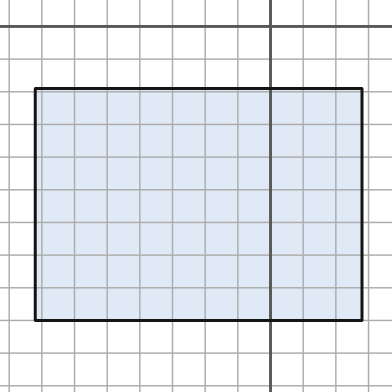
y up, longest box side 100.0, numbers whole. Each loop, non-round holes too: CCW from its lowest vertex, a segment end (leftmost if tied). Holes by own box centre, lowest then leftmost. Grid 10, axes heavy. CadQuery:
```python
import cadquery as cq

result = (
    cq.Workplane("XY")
    .moveTo(-72.0, -90.0)
    .lineTo(28.0, -90.0)
    .lineTo(28.0, -19.0)
    .lineTo(-72.0, -19.0)
    .close()
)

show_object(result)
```